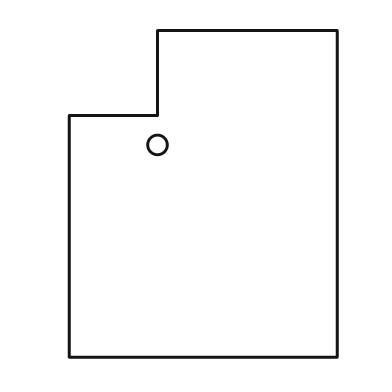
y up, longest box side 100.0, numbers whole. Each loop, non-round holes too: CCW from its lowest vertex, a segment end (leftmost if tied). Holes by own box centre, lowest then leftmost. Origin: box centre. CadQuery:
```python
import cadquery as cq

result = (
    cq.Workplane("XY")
    .moveTo(-41.0, -50.0)
    .lineTo(41.0, -50.0)
    .lineTo(41.0, 50.0)
    .lineTo(-14.0, 50.0)
    .lineTo(-14.0, 24.0)
    .lineTo(-41.0, 24.0)
    .close()
    .moveTo(-14.0, 15.0)
    .circle(3.0)
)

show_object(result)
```